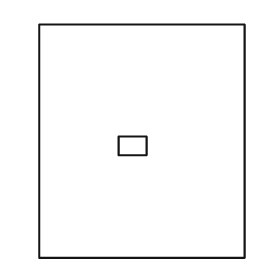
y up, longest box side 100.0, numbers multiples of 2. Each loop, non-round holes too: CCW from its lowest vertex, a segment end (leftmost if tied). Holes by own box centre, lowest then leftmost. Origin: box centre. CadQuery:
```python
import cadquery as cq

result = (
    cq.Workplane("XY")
    .moveTo(-44.0, -50.0)
    .lineTo(44.0, -50.0)
    .lineTo(44.0, 50.0)
    .lineTo(-44.0, 50.0)
    .close()
    .moveTo(-10.0, -6.0)
    .lineTo(2.0, -6.0)
    .lineTo(2.0, 2.0)
    .lineTo(-10.0, 2.0)
    .close()
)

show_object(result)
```